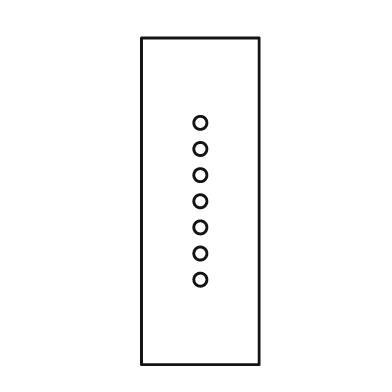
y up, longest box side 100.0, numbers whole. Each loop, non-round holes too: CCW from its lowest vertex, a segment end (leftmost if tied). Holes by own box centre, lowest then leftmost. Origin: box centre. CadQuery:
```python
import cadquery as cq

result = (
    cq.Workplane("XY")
    .moveTo(-18.0, -50.0)
    .lineTo(18.0, -50.0)
    .lineTo(18.0, 50.0)
    .lineTo(-18.0, 50.0)
    .close()
    .moveTo(0.0, -24.0)
    .circle(2.0)
    .moveTo(0.0, -16.0)
    .circle(2.0)
    .moveTo(0.0, -8.0)
    .circle(2.0)
    .moveTo(0.0, 0.0)
    .circle(2.0)
    .moveTo(0.0, 8.0)
    .circle(2.0)
    .moveTo(0.0, 16.0)
    .circle(2.0)
    .moveTo(0.0, 24.0)
    .circle(2.0)
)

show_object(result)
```